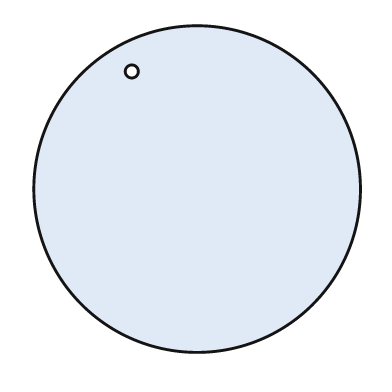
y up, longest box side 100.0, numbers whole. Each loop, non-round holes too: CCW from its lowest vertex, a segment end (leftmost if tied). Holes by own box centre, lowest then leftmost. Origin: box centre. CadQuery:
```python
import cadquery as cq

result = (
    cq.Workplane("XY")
    .moveTo(0.0, 0.0)
    .circle(50.0)
    .moveTo(-20.0, 36.0)
    .circle(2.0)
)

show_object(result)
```